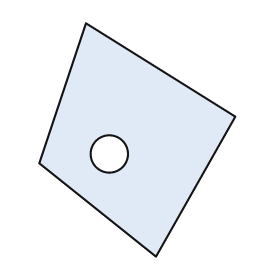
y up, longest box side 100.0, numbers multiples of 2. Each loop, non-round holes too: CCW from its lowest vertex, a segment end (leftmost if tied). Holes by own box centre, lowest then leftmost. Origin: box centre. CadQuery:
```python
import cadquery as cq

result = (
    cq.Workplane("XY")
    .moveTo(8.0, -50.0)
    .lineTo(42.0, 10.0)
    .lineTo(-22.0, 50.0)
    .lineTo(-42.0, -10.0)
    .close()
    .moveTo(-12.0, -6.0)
    .circle(8.0)
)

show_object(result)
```